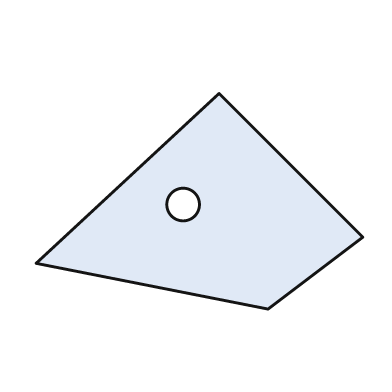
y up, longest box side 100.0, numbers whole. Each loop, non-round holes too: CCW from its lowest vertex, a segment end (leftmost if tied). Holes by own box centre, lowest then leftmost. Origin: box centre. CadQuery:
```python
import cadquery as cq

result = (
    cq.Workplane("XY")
    .moveTo(21.0, -33.0)
    .lineTo(50.0, -11.0)
    .lineTo(6.0, 33.0)
    .lineTo(-50.0, -19.0)
    .close()
    .moveTo(-5.0, -1.0)
    .circle(5.0)
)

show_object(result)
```